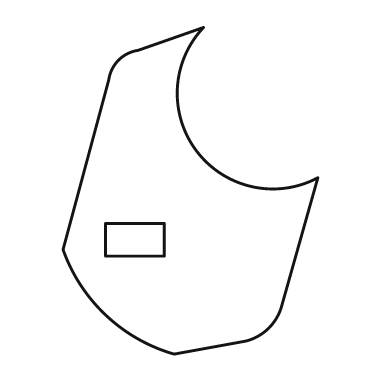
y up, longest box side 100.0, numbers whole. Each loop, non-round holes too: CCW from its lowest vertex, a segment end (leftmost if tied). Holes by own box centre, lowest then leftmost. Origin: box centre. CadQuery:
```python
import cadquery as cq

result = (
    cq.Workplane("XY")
    .moveTo(-5.0, -50.0)
    .lineTo(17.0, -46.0)
    .threePointArc((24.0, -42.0), (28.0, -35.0))
    .lineTo(39.0, 4.0)
    .threePointArc((2.0, 12.0), (4.0, 50.0))
    .lineTo(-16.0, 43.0)
    .threePointArc((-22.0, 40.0), (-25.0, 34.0))
    .lineTo(-39.0, -18.0)
    .threePointArc((-26.0, -38.0), (-5.0, -50.0))
    .close()
    .moveTo(-26.0, -20.0)
    .lineTo(-8.0, -20.0)
    .lineTo(-8.0, -10.0)
    .lineTo(-26.0, -10.0)
    .close()
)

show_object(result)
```